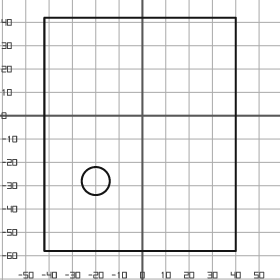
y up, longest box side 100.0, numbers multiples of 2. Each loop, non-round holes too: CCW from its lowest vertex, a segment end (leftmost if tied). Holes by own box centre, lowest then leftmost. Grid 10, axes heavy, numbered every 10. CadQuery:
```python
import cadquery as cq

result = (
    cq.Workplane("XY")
    .moveTo(-42.0, -58.0)
    .lineTo(40.0, -58.0)
    .lineTo(40.0, 42.0)
    .lineTo(-42.0, 42.0)
    .close()
    .moveTo(-20.0, -28.0)
    .circle(6.0)
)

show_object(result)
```